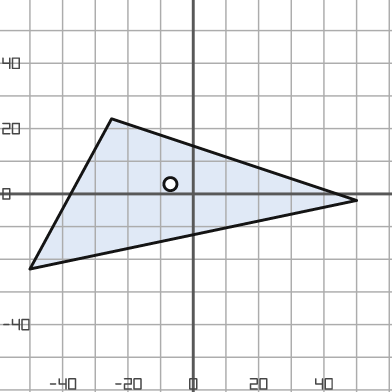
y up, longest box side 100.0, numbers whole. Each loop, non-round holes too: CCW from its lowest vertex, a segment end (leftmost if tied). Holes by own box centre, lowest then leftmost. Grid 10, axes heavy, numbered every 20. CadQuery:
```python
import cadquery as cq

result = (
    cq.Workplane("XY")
    .moveTo(-50.0, -23.0)
    .lineTo(50.0, -2.0)
    .lineTo(-25.0, 23.0)
    .close()
    .moveTo(-7.0, 3.0)
    .circle(2.0)
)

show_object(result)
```